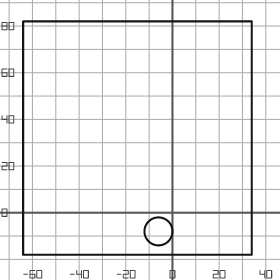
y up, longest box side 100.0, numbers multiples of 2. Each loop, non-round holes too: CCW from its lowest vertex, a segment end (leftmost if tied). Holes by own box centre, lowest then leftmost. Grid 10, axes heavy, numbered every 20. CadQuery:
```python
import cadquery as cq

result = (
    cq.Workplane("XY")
    .moveTo(-64.0, -18.0)
    .lineTo(34.0, -18.0)
    .lineTo(34.0, 82.0)
    .lineTo(-64.0, 82.0)
    .close()
    .moveTo(-6.0, -8.0)
    .circle(6.0)
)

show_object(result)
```